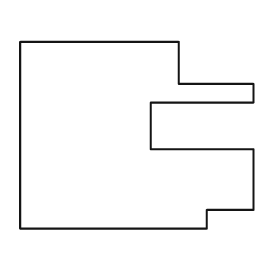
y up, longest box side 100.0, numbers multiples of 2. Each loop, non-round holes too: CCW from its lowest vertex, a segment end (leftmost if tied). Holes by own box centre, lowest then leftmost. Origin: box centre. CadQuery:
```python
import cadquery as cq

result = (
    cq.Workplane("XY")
    .moveTo(-50.0, -40.0)
    .lineTo(30.0, -40.0)
    .lineTo(30.0, -32.0)
    .lineTo(50.0, -32.0)
    .lineTo(50.0, -6.0)
    .lineTo(6.0, -6.0)
    .lineTo(6.0, 14.0)
    .lineTo(50.0, 14.0)
    .lineTo(50.0, 22.0)
    .lineTo(18.0, 22.0)
    .lineTo(18.0, 40.0)
    .lineTo(-50.0, 40.0)
    .close()
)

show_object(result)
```